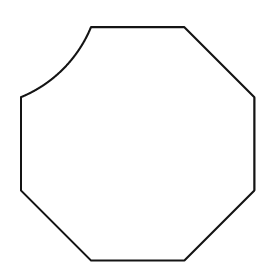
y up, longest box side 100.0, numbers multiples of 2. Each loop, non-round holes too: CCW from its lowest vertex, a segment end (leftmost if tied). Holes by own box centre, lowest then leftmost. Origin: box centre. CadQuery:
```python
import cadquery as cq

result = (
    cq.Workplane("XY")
    .moveTo(-20.0, -50.0)
    .lineTo(20.0, -50.0)
    .lineTo(50.0, -20.0)
    .lineTo(50.0, 20.0)
    .lineTo(20.0, 50.0)
    .lineTo(-20.0, 50.0)
    .threePointArc((-32.0, 32.0), (-50.0, 20.0))
    .lineTo(-50.0, -20.0)
    .close()
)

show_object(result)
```